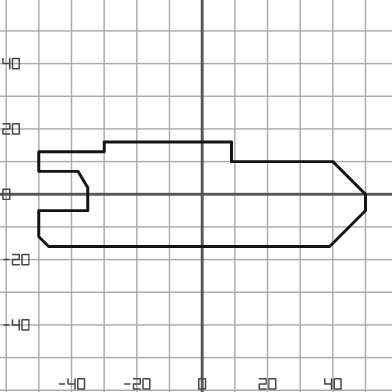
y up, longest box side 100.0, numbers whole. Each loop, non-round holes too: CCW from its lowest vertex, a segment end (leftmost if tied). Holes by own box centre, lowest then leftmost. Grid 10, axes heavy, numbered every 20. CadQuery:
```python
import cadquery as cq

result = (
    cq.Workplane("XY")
    .moveTo(-47.0, -16.0)
    .lineTo(39.0, -16.0)
    .lineTo(50.0, -5.0)
    .lineTo(50.0, 0.0)
    .lineTo(40.0, 10.0)
    .lineTo(9.0, 10.0)
    .lineTo(9.0, 16.0)
    .lineTo(-30.0, 16.0)
    .lineTo(-30.0, 13.0)
    .lineTo(-50.0, 13.0)
    .lineTo(-50.0, 7.0)
    .lineTo(-38.0, 7.0)
    .lineTo(-35.0, 2.0)
    .lineTo(-35.0, -5.0)
    .lineTo(-50.0, -5.0)
    .lineTo(-50.0, -13.0)
    .close()
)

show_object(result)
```